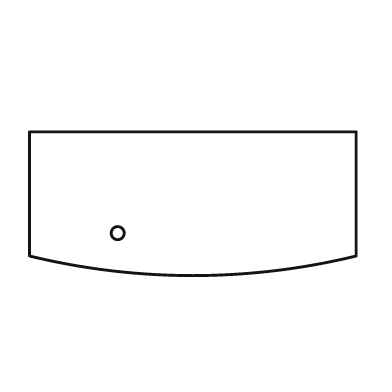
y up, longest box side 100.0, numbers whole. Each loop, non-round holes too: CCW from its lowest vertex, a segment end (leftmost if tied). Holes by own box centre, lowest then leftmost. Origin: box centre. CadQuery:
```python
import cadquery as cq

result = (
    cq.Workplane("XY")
    .moveTo(-50.0, -16.0)
    .threePointArc((0.0, -22.0), (50.0, -16.0))
    .lineTo(50.0, 22.0)
    .lineTo(-50.0, 22.0)
    .close()
    .moveTo(-23.0, -9.0)
    .circle(2.0)
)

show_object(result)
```